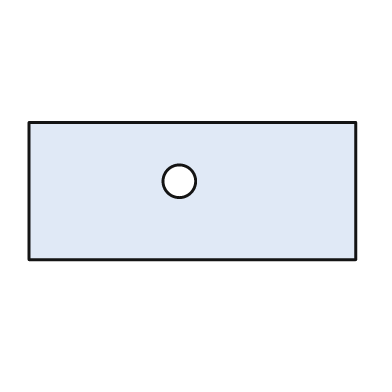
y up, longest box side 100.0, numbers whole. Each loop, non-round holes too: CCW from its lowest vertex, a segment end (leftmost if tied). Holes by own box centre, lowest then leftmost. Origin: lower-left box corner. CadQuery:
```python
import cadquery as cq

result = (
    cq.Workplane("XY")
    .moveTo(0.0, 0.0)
    .lineTo(100.0, 0.0)
    .lineTo(100.0, 42.0)
    .lineTo(0.0, 42.0)
    .close()
    .moveTo(46.0, 24.0)
    .circle(5.0)
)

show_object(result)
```